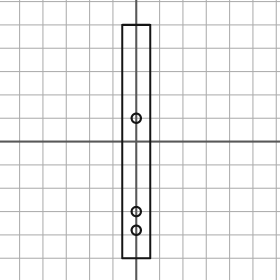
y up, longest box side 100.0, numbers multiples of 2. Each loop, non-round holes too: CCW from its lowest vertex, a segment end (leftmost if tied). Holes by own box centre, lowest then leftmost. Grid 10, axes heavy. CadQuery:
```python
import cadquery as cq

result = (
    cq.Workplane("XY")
    .moveTo(-6.0, -50.0)
    .lineTo(6.0, -50.0)
    .lineTo(6.0, 50.0)
    .lineTo(-6.0, 50.0)
    .close()
    .moveTo(0.0, -38.0)
    .circle(2.0)
    .moveTo(0.0, -30.0)
    .circle(2.0)
    .moveTo(0.0, 10.0)
    .circle(2.0)
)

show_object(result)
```